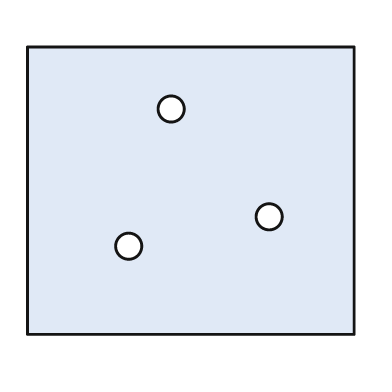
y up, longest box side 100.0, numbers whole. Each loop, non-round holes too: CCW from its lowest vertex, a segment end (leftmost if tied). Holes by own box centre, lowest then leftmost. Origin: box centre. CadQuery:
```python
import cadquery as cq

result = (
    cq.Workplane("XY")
    .moveTo(-50.0, -44.0)
    .lineTo(50.0, -44.0)
    .lineTo(50.0, 44.0)
    .lineTo(-50.0, 44.0)
    .close()
    .moveTo(-19.0, -17.0)
    .circle(4.0)
    .moveTo(24.0, -8.0)
    .circle(4.0)
    .moveTo(-6.0, 25.0)
    .circle(4.0)
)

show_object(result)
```